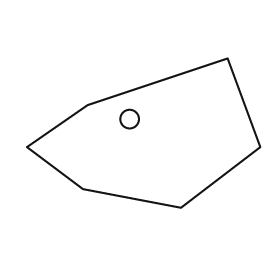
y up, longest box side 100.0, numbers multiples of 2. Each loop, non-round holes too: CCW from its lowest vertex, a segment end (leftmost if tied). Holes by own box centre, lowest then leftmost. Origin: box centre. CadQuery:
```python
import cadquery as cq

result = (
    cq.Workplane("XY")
    .moveTo(16.0, -32.0)
    .lineTo(50.0, -6.0)
    .lineTo(36.0, 32.0)
    .lineTo(-24.0, 12.0)
    .lineTo(-50.0, -6.0)
    .lineTo(-26.0, -24.0)
    .close()
    .moveTo(-6.0, 6.0)
    .circle(4.0)
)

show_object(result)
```